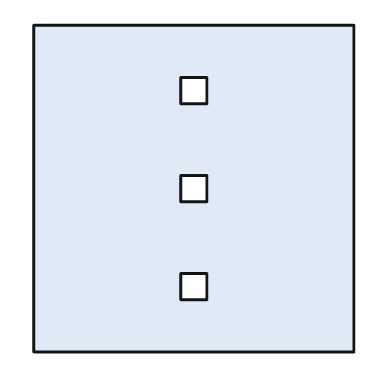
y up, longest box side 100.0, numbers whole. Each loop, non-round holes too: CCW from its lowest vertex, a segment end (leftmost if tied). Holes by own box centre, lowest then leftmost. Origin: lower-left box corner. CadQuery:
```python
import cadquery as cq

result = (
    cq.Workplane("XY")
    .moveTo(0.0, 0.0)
    .lineTo(98.0, 0.0)
    .lineTo(98.0, 100.0)
    .lineTo(0.0, 100.0)
    .close()
    .moveTo(45.0, 16.0)
    .lineTo(53.0, 16.0)
    .lineTo(53.0, 24.0)
    .lineTo(45.0, 24.0)
    .close()
    .moveTo(45.0, 46.0)
    .lineTo(53.0, 46.0)
    .lineTo(53.0, 54.0)
    .lineTo(45.0, 54.0)
    .close()
    .moveTo(45.0, 76.0)
    .lineTo(53.0, 76.0)
    .lineTo(53.0, 84.0)
    .lineTo(45.0, 84.0)
    .close()
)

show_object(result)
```